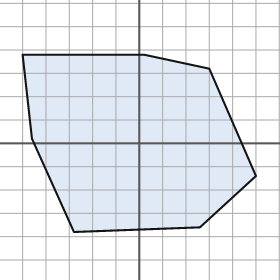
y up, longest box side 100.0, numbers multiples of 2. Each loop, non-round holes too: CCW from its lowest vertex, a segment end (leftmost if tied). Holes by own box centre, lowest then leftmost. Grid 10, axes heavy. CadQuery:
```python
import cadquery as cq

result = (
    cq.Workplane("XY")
    .moveTo(-28.0, -38.0)
    .lineTo(26.0, -36.0)
    .lineTo(50.0, -14.0)
    .lineTo(30.0, 32.0)
    .lineTo(2.0, 38.0)
    .lineTo(-50.0, 38.0)
    .lineTo(-46.0, 2.0)
    .close()
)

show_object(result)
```